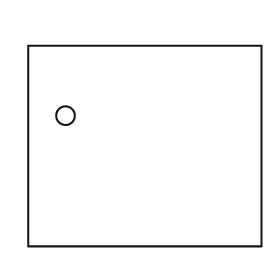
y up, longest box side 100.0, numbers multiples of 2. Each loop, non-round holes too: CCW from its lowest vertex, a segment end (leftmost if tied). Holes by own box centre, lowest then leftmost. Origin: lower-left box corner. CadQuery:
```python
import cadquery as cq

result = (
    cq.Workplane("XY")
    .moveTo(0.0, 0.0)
    .lineTo(100.0, 0.0)
    .lineTo(100.0, 86.0)
    .lineTo(0.0, 86.0)
    .close()
    .moveTo(16.0, 56.0)
    .circle(4.0)
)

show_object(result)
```